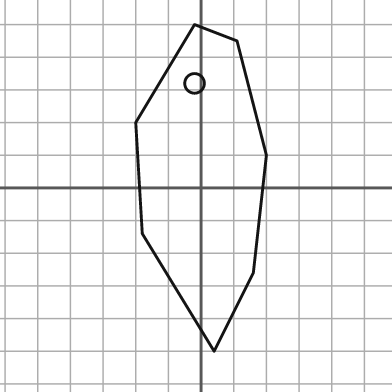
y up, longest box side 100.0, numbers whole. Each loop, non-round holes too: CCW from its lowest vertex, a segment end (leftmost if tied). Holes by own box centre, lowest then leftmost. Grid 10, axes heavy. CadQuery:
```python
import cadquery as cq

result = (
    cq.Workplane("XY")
    .moveTo(4.0, -50.0)
    .lineTo(16.0, -26.0)
    .lineTo(20.0, 10.0)
    .lineTo(11.0, 45.0)
    .lineTo(-2.0, 50.0)
    .lineTo(-20.0, 20.0)
    .lineTo(-18.0, -14.0)
    .close()
    .moveTo(-2.0, 32.0)
    .circle(3.0)
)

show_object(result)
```